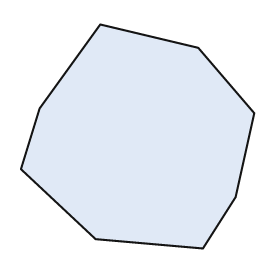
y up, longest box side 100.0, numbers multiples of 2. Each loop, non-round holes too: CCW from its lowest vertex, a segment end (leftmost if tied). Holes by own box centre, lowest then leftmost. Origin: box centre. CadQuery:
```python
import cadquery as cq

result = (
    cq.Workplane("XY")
    .moveTo(28.0, -48.0)
    .lineTo(42.0, -26.0)
    .lineTo(50.0, 10.0)
    .lineTo(26.0, 38.0)
    .lineTo(-16.0, 48.0)
    .lineTo(-42.0, 12.0)
    .lineTo(-50.0, -14.0)
    .lineTo(-18.0, -44.0)
    .close()
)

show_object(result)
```